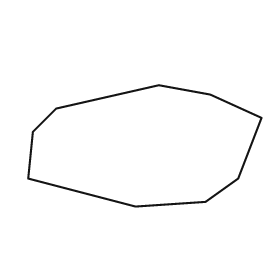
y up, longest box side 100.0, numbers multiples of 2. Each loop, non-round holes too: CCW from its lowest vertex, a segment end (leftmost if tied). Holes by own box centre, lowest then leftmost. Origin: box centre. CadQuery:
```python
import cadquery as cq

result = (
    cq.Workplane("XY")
    .moveTo(-4.0, -26.0)
    .lineTo(26.0, -24.0)
    .lineTo(40.0, -14.0)
    .lineTo(50.0, 12.0)
    .lineTo(28.0, 22.0)
    .lineTo(6.0, 26.0)
    .lineTo(-38.0, 16.0)
    .lineTo(-48.0, 6.0)
    .lineTo(-50.0, -14.0)
    .close()
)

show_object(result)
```